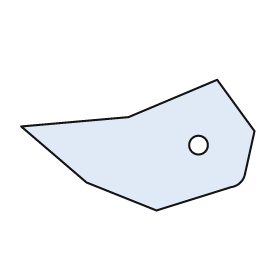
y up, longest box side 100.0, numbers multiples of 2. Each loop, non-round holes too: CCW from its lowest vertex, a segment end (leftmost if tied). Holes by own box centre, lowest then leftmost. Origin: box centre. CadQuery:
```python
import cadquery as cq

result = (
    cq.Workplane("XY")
    .moveTo(8.0, -28.0)
    .lineTo(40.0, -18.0)
    .threePointArc((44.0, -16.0), (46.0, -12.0))
    .lineTo(50.0, 6.0)
    .lineTo(34.0, 28.0)
    .lineTo(-4.0, 12.0)
    .lineTo(-50.0, 8.0)
    .lineTo(-22.0, -16.0)
    .close()
    .moveTo(26.0, 0.0)
    .circle(4.0)
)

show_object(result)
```